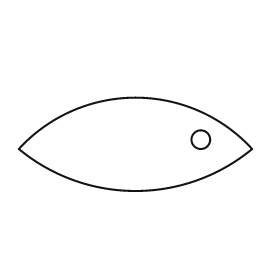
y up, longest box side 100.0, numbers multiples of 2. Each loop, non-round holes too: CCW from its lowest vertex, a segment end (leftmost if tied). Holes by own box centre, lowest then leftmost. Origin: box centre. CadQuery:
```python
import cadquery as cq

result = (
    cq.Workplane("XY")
    .moveTo(-50.0, -2.0)
    .threePointArc((0.0, -20.0), (50.0, -2.0))
    .threePointArc((0.0, 20.0), (-50.0, -2.0))
    .close()
    .moveTo(28.0, 2.0)
    .circle(4.0)
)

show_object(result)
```